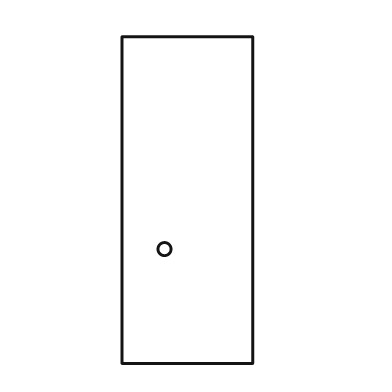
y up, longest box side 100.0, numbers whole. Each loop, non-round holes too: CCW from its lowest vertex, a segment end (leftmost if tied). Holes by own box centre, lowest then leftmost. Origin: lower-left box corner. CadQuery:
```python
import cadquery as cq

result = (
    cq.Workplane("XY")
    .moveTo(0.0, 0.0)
    .lineTo(40.0, 0.0)
    .lineTo(40.0, 100.0)
    .lineTo(0.0, 100.0)
    .close()
    .moveTo(13.0, 35.0)
    .circle(2.0)
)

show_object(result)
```